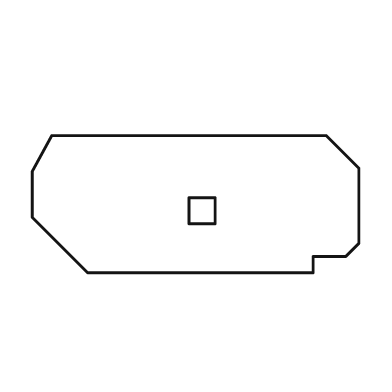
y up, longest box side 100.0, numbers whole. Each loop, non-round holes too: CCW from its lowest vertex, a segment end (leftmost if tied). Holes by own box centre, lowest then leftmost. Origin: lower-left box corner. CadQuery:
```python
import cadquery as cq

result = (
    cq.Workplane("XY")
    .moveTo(17.0, 0.0)
    .lineTo(86.0, 0.0)
    .lineTo(86.0, 5.0)
    .lineTo(96.0, 5.0)
    .lineTo(100.0, 9.0)
    .lineTo(100.0, 32.0)
    .lineTo(90.0, 42.0)
    .lineTo(6.0, 42.0)
    .lineTo(0.0, 31.0)
    .lineTo(0.0, 17.0)
    .close()
    .moveTo(48.0, 15.0)
    .lineTo(56.0, 15.0)
    .lineTo(56.0, 23.0)
    .lineTo(48.0, 23.0)
    .close()
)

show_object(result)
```